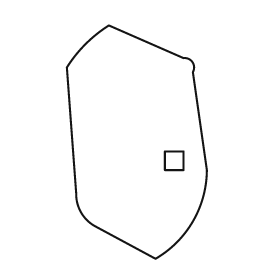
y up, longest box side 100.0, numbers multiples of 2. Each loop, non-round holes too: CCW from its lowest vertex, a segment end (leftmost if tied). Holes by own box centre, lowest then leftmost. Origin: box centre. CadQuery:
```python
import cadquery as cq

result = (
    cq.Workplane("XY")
    .moveTo(8.0, -50.0)
    .threePointArc((24.0, -34.0), (30.0, -12.0))
    .lineTo(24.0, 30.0)
    .threePointArc((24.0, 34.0), (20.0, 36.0))
    .lineTo(-12.0, 50.0)
    .threePointArc((-22.0, 42.0), (-30.0, 32.0))
    .lineTo(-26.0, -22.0)
    .threePointArc((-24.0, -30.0), (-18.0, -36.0))
    .close()
    .moveTo(12.0, -12.0)
    .lineTo(20.0, -12.0)
    .lineTo(20.0, -4.0)
    .lineTo(12.0, -4.0)
    .close()
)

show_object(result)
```